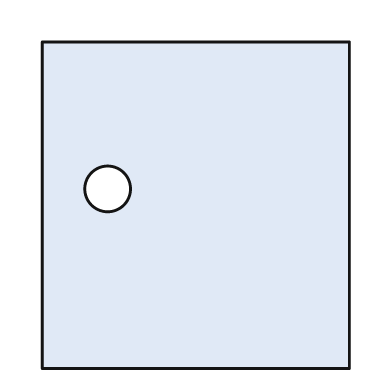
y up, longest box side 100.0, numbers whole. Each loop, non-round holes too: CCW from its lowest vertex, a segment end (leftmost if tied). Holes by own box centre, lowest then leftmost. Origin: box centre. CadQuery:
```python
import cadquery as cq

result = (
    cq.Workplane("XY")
    .moveTo(-47.0, -50.0)
    .lineTo(47.0, -50.0)
    .lineTo(47.0, 50.0)
    .lineTo(-47.0, 50.0)
    .close()
    .moveTo(-27.0, 5.0)
    .circle(7.0)
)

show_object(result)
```